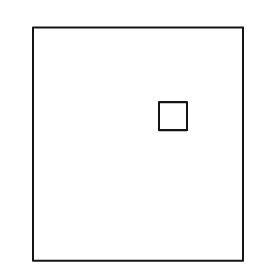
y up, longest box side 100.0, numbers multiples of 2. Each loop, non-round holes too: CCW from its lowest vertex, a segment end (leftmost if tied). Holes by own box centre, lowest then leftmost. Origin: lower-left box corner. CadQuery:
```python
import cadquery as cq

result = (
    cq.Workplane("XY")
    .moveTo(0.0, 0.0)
    .lineTo(90.0, 0.0)
    .lineTo(90.0, 100.0)
    .lineTo(0.0, 100.0)
    .close()
    .moveTo(54.0, 56.0)
    .lineTo(66.0, 56.0)
    .lineTo(66.0, 68.0)
    .lineTo(54.0, 68.0)
    .close()
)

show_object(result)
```